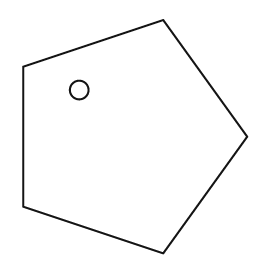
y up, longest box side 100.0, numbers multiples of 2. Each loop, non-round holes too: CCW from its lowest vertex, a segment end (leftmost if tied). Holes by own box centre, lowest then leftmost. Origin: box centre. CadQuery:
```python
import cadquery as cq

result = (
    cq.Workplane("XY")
    .moveTo(12.0, -50.0)
    .lineTo(48.0, 0.0)
    .lineTo(12.0, 50.0)
    .lineTo(-48.0, 30.0)
    .lineTo(-48.0, -30.0)
    .close()
    .moveTo(-24.0, 20.0)
    .circle(4.0)
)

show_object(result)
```